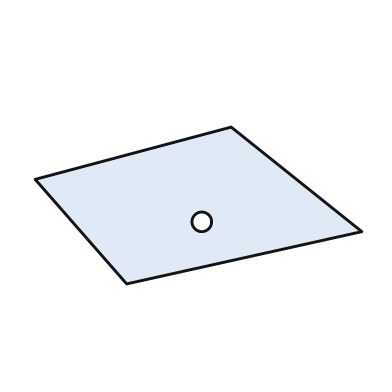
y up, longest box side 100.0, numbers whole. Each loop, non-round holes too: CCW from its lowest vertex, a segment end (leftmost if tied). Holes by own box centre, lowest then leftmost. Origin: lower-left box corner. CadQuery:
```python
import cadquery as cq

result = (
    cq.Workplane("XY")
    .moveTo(28.0, 0.0)
    .lineTo(100.0, 16.0)
    .lineTo(60.0, 48.0)
    .lineTo(0.0, 32.0)
    .close()
    .moveTo(51.0, 19.0)
    .circle(3.0)
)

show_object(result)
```